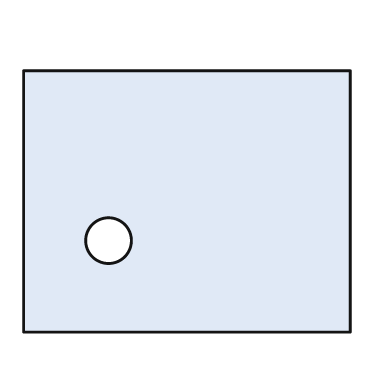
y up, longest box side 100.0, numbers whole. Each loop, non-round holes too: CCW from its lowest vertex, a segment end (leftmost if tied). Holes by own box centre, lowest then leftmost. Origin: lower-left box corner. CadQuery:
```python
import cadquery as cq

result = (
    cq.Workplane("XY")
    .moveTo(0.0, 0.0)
    .lineTo(100.0, 0.0)
    .lineTo(100.0, 80.0)
    .lineTo(0.0, 80.0)
    .close()
    .moveTo(26.0, 28.0)
    .circle(7.0)
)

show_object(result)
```